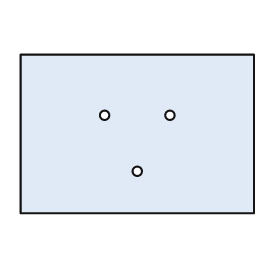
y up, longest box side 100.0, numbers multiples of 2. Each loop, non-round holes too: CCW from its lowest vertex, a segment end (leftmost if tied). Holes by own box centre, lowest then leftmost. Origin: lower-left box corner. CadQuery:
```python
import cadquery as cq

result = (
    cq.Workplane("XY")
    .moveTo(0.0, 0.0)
    .lineTo(100.0, 0.0)
    .lineTo(100.0, 68.0)
    .lineTo(0.0, 68.0)
    .close()
    .moveTo(50.0, 18.0)
    .circle(2.0)
    .moveTo(36.0, 42.0)
    .circle(2.0)
    .moveTo(64.0, 42.0)
    .circle(2.0)
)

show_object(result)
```